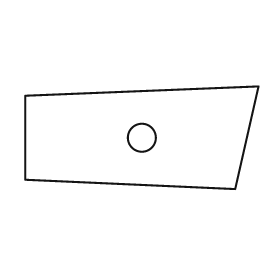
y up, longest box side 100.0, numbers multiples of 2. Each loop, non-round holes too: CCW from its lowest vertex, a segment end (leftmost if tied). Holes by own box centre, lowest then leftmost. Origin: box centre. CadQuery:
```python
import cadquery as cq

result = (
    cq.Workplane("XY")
    .moveTo(40.0, -22.0)
    .lineTo(50.0, 22.0)
    .lineTo(-50.0, 18.0)
    .lineTo(-50.0, -18.0)
    .close()
    .moveTo(0.0, 0.0)
    .circle(6.0)
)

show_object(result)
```